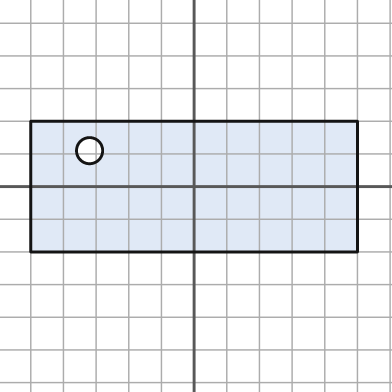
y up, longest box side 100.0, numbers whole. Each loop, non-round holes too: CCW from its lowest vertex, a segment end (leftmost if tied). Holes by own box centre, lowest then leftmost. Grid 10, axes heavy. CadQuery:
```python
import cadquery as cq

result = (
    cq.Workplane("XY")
    .moveTo(-50.0, -20.0)
    .lineTo(50.0, -20.0)
    .lineTo(50.0, 20.0)
    .lineTo(-50.0, 20.0)
    .close()
    .moveTo(-32.0, 11.0)
    .circle(4.0)
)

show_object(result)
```